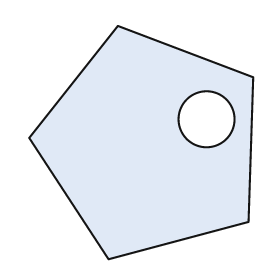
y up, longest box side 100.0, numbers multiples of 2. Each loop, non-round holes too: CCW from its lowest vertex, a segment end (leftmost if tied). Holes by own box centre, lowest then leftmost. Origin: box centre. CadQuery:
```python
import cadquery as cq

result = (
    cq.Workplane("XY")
    .moveTo(-14.0, -50.0)
    .lineTo(46.0, -34.0)
    .lineTo(48.0, 28.0)
    .lineTo(-10.0, 50.0)
    .lineTo(-48.0, 2.0)
    .close()
    .moveTo(28.0, 10.0)
    .circle(12.0)
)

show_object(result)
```